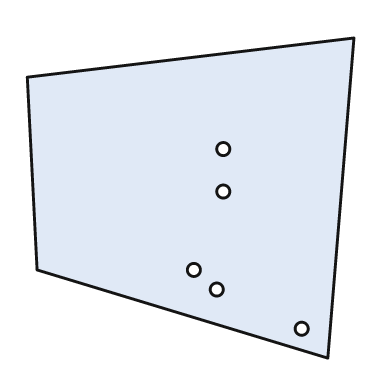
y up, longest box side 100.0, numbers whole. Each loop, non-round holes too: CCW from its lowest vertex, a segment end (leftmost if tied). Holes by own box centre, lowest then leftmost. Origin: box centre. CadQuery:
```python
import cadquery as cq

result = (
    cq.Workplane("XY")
    .moveTo(42.0, -49.0)
    .lineTo(50.0, 49.0)
    .lineTo(-50.0, 37.0)
    .lineTo(-47.0, -22.0)
    .close()
    .moveTo(34.0, -40.0)
    .circle(2.0)
    .moveTo(8.0, -28.0)
    .circle(2.0)
    .moveTo(1.0, -22.0)
    .circle(2.0)
    .moveTo(10.0, 2.0)
    .circle(2.0)
    .moveTo(10.0, 15.0)
    .circle(2.0)
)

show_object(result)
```